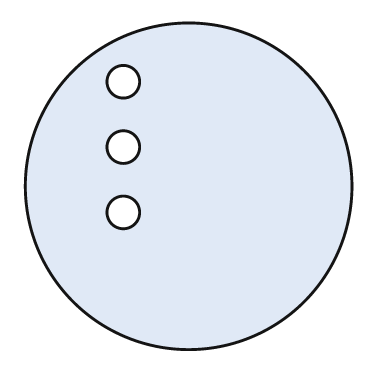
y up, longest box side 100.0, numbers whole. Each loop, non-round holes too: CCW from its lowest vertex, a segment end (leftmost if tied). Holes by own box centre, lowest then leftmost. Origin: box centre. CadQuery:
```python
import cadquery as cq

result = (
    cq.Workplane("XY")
    .moveTo(0.0, 0.0)
    .circle(50.0)
    .moveTo(-20.0, -8.0)
    .circle(5.0)
    .moveTo(-20.0, 12.0)
    .circle(5.0)
    .moveTo(-20.0, 32.0)
    .circle(5.0)
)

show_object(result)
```